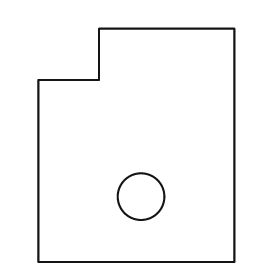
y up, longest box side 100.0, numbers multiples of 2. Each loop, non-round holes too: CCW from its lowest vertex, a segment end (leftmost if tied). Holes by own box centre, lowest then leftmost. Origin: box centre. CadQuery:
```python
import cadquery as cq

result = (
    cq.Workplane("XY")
    .moveTo(-42.0, -50.0)
    .lineTo(42.0, -50.0)
    .lineTo(42.0, 50.0)
    .lineTo(-16.0, 50.0)
    .lineTo(-16.0, 28.0)
    .lineTo(-42.0, 28.0)
    .close()
    .moveTo(2.0, -22.0)
    .circle(10.0)
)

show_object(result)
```